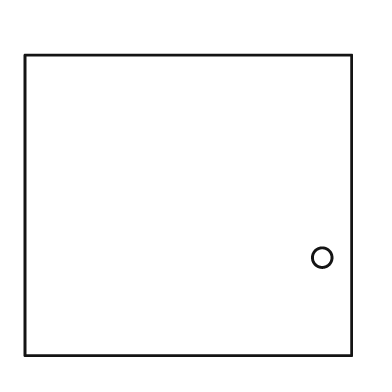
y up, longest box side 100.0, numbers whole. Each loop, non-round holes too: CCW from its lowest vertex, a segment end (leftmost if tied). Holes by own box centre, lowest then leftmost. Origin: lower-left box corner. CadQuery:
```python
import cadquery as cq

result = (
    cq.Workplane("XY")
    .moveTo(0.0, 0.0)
    .lineTo(100.0, 0.0)
    .lineTo(100.0, 92.0)
    .lineTo(0.0, 92.0)
    .close()
    .moveTo(91.0, 30.0)
    .circle(3.0)
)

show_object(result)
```